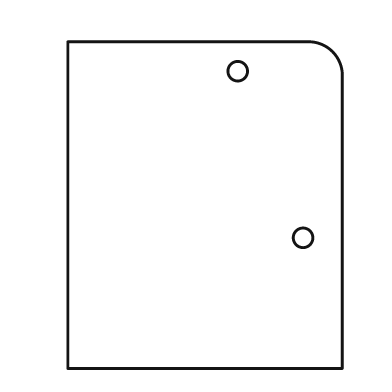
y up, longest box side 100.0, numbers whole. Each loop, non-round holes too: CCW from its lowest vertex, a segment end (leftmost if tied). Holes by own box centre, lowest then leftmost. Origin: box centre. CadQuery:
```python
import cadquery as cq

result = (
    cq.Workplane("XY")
    .moveTo(-42.0, -50.0)
    .lineTo(42.0, -50.0)
    .lineTo(42.0, 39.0)
    .threePointArc((39.0, 47.0), (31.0, 50.0))
    .lineTo(-42.0, 50.0)
    .close()
    .moveTo(30.0, -10.0)
    .circle(3.0)
    .moveTo(10.0, 41.0)
    .circle(3.0)
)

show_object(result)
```